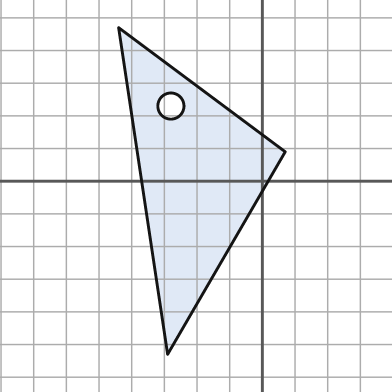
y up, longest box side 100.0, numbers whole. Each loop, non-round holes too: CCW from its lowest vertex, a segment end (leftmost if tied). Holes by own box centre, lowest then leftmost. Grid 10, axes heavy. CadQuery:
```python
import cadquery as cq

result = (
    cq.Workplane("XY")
    .moveTo(-29.0, -53.0)
    .lineTo(7.0, 9.0)
    .lineTo(-44.0, 47.0)
    .close()
    .moveTo(-28.0, 23.0)
    .circle(4.0)
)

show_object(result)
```